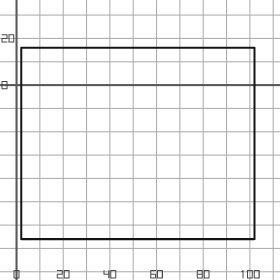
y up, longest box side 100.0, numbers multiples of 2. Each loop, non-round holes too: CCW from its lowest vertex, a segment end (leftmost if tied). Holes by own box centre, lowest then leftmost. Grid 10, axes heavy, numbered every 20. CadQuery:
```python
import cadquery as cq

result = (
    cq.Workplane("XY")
    .moveTo(2.0, -66.0)
    .lineTo(102.0, -66.0)
    .lineTo(102.0, 16.0)
    .lineTo(2.0, 16.0)
    .close()
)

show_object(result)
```